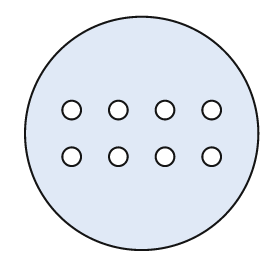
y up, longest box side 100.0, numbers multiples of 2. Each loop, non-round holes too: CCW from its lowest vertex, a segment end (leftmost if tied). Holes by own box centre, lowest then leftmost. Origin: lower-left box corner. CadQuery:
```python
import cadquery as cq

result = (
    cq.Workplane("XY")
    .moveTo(50.0, 50.0)
    .circle(50.0)
    .moveTo(20.0, 40.0)
    .circle(4.0)
    .moveTo(40.0, 40.0)
    .circle(4.0)
    .moveTo(60.0, 40.0)
    .circle(4.0)
    .moveTo(80.0, 40.0)
    .circle(4.0)
    .moveTo(20.0, 60.0)
    .circle(4.0)
    .moveTo(40.0, 60.0)
    .circle(4.0)
    .moveTo(60.0, 60.0)
    .circle(4.0)
    .moveTo(80.0, 60.0)
    .circle(4.0)
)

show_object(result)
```